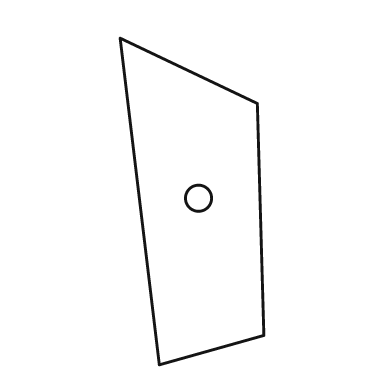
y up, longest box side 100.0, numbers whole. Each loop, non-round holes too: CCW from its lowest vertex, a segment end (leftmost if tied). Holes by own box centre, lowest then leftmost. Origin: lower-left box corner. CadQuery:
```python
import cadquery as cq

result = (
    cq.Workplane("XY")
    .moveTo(12.0, 0.0)
    .lineTo(44.0, 9.0)
    .lineTo(42.0, 80.0)
    .lineTo(0.0, 100.0)
    .close()
    .moveTo(24.0, 51.0)
    .circle(4.0)
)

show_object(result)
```